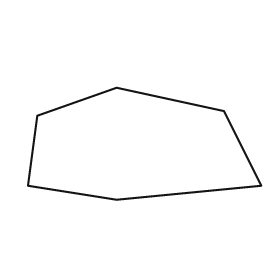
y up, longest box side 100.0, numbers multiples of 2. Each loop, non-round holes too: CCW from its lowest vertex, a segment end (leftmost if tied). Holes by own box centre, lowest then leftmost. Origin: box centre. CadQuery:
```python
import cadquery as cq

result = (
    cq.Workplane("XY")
    .moveTo(-12.0, -24.0)
    .lineTo(50.0, -18.0)
    .lineTo(34.0, 14.0)
    .lineTo(-12.0, 24.0)
    .lineTo(-46.0, 12.0)
    .lineTo(-50.0, -18.0)
    .close()
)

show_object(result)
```